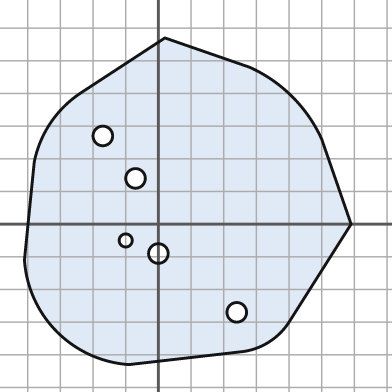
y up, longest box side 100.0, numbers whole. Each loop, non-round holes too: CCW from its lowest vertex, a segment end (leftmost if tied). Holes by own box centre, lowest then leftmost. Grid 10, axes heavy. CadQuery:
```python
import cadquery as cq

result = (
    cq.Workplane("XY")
    .moveTo(-9.0, -43.0)
    .lineTo(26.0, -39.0)
    .threePointArc((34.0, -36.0), (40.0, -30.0))
    .lineTo(59.0, 0.0)
    .lineTo(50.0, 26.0)
    .threePointArc((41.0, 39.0), (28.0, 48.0))
    .lineTo(2.0, 57.0)
    .lineTo(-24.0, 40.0)
    .threePointArc((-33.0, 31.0), (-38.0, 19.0))
    .lineTo(-41.0, -11.0)
    .threePointArc((-31.0, -33.0), (-9.0, -43.0))
    .close()
    .moveTo(24.0, -27.0)
    .circle(3.0)
    .moveTo(0.0, -9.0)
    .circle(3.0)
    .moveTo(-10.0, -5.0)
    .circle(2.0)
    .moveTo(-7.0, 14.0)
    .circle(3.0)
    .moveTo(-17.0, 27.0)
    .circle(3.0)
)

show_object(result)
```